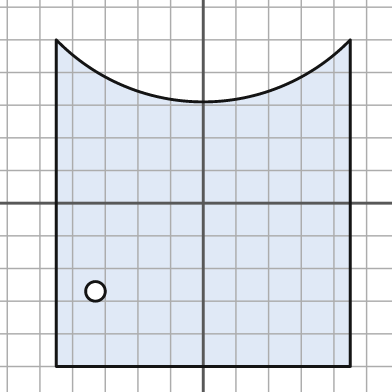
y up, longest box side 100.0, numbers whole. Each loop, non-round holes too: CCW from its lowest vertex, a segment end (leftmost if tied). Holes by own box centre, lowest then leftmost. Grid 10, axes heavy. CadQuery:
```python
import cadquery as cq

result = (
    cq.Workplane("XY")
    .moveTo(-45.0, -50.0)
    .lineTo(45.0, -50.0)
    .lineTo(45.0, 50.0)
    .threePointArc((0.0, 31.0), (-45.0, 50.0))
    .close()
    .moveTo(-33.0, -27.0)
    .circle(3.0)
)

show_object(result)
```